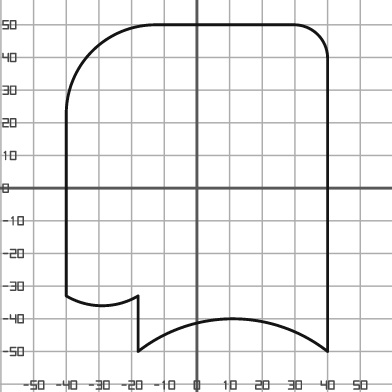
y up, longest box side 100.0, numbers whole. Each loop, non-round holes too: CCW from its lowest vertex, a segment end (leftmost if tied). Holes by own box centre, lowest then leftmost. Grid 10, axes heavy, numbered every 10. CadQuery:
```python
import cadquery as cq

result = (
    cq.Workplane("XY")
    .moveTo(-18.0, -50.0)
    .threePointArc((11.0, -40.0), (40.0, -50.0))
    .lineTo(40.0, 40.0)
    .threePointArc((37.0, 47.0), (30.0, 50.0))
    .lineTo(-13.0, 50.0)
    .threePointArc((-32.0, 42.0), (-40.0, 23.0))
    .lineTo(-40.0, -33.0)
    .threePointArc((-29.0, -36.0), (-18.0, -33.0))
    .close()
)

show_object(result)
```